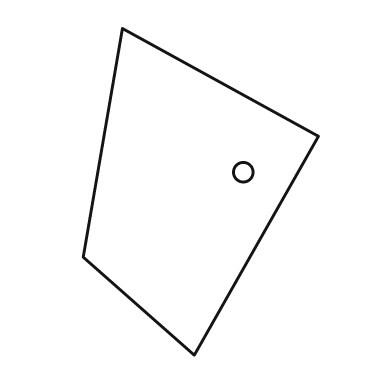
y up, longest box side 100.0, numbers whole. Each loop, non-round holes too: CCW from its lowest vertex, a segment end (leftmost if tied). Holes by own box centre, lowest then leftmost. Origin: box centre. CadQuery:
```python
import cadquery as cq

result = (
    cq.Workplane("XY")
    .moveTo(-2.0, -50.0)
    .lineTo(36.0, 17.0)
    .lineTo(-24.0, 50.0)
    .lineTo(-36.0, -20.0)
    .close()
    .moveTo(13.0, 6.0)
    .circle(3.0)
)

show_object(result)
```